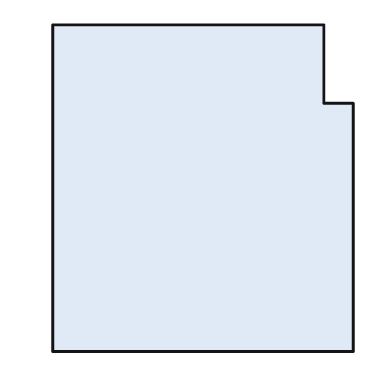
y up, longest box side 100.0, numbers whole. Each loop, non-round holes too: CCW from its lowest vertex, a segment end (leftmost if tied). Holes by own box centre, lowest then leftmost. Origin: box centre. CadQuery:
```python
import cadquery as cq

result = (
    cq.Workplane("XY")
    .moveTo(-46.0, -50.0)
    .lineTo(46.0, -50.0)
    .lineTo(46.0, 26.0)
    .lineTo(37.0, 26.0)
    .lineTo(37.0, 50.0)
    .lineTo(-46.0, 50.0)
    .close()
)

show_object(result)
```